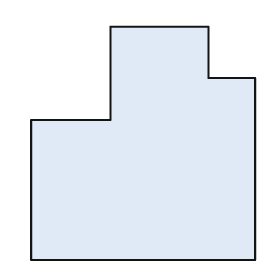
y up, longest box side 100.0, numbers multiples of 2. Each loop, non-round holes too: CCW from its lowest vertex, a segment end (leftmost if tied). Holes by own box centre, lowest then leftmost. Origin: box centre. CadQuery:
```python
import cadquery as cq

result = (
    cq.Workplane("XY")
    .moveTo(-48.0, -50.0)
    .lineTo(48.0, -50.0)
    .lineTo(48.0, 28.0)
    .lineTo(28.0, 28.0)
    .lineTo(28.0, 50.0)
    .lineTo(-14.0, 50.0)
    .lineTo(-14.0, 10.0)
    .lineTo(-48.0, 10.0)
    .close()
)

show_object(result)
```